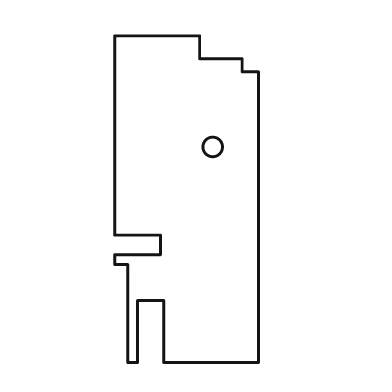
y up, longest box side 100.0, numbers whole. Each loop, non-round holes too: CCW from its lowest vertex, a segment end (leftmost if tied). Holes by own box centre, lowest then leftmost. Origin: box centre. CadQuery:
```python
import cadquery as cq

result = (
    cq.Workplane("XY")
    .moveTo(-18.0, -50.0)
    .lineTo(-15.0, -50.0)
    .lineTo(-15.0, -31.0)
    .lineTo(-7.0, -31.0)
    .lineTo(-7.0, -50.0)
    .lineTo(22.0, -50.0)
    .lineTo(22.0, 39.0)
    .lineTo(17.0, 39.0)
    .lineTo(17.0, 43.0)
    .lineTo(4.0, 43.0)
    .lineTo(4.0, 50.0)
    .lineTo(-22.0, 50.0)
    .lineTo(-22.0, -11.0)
    .lineTo(-8.0, -11.0)
    .lineTo(-8.0, -17.0)
    .lineTo(-22.0, -17.0)
    .lineTo(-22.0, -20.0)
    .lineTo(-18.0, -20.0)
    .close()
    .moveTo(8.0, 16.0)
    .circle(3.0)
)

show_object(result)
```